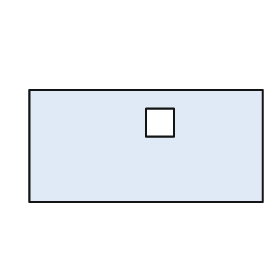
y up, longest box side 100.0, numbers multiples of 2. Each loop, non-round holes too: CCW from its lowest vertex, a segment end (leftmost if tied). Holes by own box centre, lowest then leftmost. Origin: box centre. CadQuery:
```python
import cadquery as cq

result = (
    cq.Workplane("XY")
    .moveTo(-50.0, -24.0)
    .lineTo(50.0, -24.0)
    .lineTo(50.0, 24.0)
    .lineTo(-50.0, 24.0)
    .close()
    .moveTo(0.0, 4.0)
    .lineTo(12.0, 4.0)
    .lineTo(12.0, 16.0)
    .lineTo(0.0, 16.0)
    .close()
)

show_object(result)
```